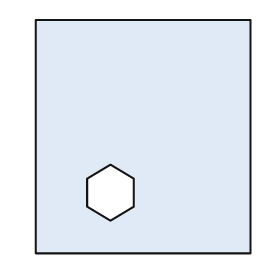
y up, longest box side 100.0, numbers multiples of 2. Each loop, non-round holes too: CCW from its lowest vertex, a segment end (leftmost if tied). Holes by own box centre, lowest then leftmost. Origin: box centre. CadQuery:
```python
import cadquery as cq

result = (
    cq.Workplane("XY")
    .moveTo(-46.0, -50.0)
    .lineTo(46.0, -50.0)
    .lineTo(46.0, 50.0)
    .lineTo(-46.0, 50.0)
    .close()
    .moveTo(-14.0, -36.0)
    .lineTo(-4.0, -30.0)
    .lineTo(-4.0, -18.0)
    .lineTo(-14.0, -12.0)
    .lineTo(-24.0, -18.0)
    .lineTo(-24.0, -30.0)
    .close()
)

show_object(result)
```